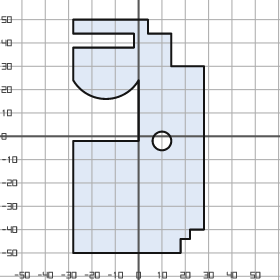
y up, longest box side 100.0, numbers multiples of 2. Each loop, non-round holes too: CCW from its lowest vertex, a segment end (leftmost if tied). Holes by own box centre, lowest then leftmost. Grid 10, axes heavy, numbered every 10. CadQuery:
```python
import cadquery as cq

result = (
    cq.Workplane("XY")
    .moveTo(-28.0, -50.0)
    .lineTo(18.0, -50.0)
    .lineTo(18.0, -44.0)
    .lineTo(22.0, -44.0)
    .lineTo(22.0, -40.0)
    .lineTo(28.0, -40.0)
    .lineTo(28.0, 30.0)
    .lineTo(14.0, 30.0)
    .lineTo(14.0, 44.0)
    .lineTo(4.0, 44.0)
    .lineTo(4.0, 50.0)
    .lineTo(-28.0, 50.0)
    .lineTo(-28.0, 44.0)
    .lineTo(-2.0, 44.0)
    .lineTo(-2.0, 38.0)
    .lineTo(-28.0, 38.0)
    .lineTo(-28.0, 24.0)
    .threePointArc((-14.0, 16.0), (0.0, 24.0))
    .lineTo(0.0, -2.0)
    .lineTo(-28.0, -2.0)
    .close()
    .moveTo(10.0, -2.0)
    .circle(4.0)
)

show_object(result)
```